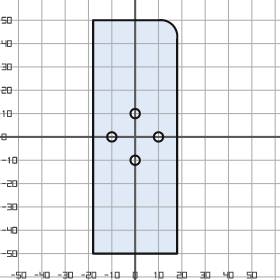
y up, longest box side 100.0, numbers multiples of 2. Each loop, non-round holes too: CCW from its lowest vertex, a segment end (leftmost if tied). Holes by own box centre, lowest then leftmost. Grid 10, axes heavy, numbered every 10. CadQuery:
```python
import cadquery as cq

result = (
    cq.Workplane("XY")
    .moveTo(-18.0, -50.0)
    .lineTo(18.0, -50.0)
    .lineTo(18.0, 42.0)
    .threePointArc((16.0, 48.0), (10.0, 50.0))
    .lineTo(-18.0, 50.0)
    .close()
    .moveTo(0.0, -10.0)
    .circle(2.0)
    .moveTo(-10.0, 0.0)
    .circle(2.0)
    .moveTo(10.0, 0.0)
    .circle(2.0)
    .moveTo(0.0, 10.0)
    .circle(2.0)
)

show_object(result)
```